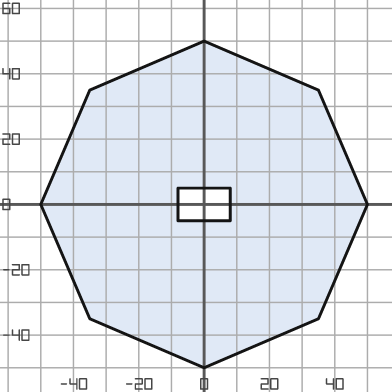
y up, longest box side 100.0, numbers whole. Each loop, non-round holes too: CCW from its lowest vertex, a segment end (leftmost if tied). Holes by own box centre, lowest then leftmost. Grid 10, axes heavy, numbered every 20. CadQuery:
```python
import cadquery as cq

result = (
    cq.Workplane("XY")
    .moveTo(0.0, -50.0)
    .lineTo(35.0, -35.0)
    .lineTo(50.0, 0.0)
    .lineTo(35.0, 35.0)
    .lineTo(0.0, 50.0)
    .lineTo(-35.0, 35.0)
    .lineTo(-50.0, 0.0)
    .lineTo(-35.0, -35.0)
    .close()
    .moveTo(-8.0, -5.0)
    .lineTo(8.0, -5.0)
    .lineTo(8.0, 5.0)
    .lineTo(-8.0, 5.0)
    .close()
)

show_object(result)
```